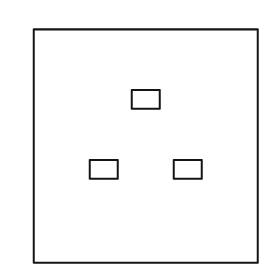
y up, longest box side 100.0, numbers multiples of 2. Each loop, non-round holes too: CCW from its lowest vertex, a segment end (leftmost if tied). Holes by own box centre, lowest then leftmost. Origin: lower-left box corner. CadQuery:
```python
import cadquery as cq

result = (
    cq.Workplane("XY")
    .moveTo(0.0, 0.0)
    .lineTo(96.0, 0.0)
    .lineTo(96.0, 100.0)
    .lineTo(0.0, 100.0)
    .close()
    .moveTo(24.0, 36.0)
    .lineTo(36.0, 36.0)
    .lineTo(36.0, 44.0)
    .lineTo(24.0, 44.0)
    .close()
    .moveTo(60.0, 36.0)
    .lineTo(72.0, 36.0)
    .lineTo(72.0, 44.0)
    .lineTo(60.0, 44.0)
    .close()
    .moveTo(42.0, 66.0)
    .lineTo(54.0, 66.0)
    .lineTo(54.0, 74.0)
    .lineTo(42.0, 74.0)
    .close()
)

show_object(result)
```